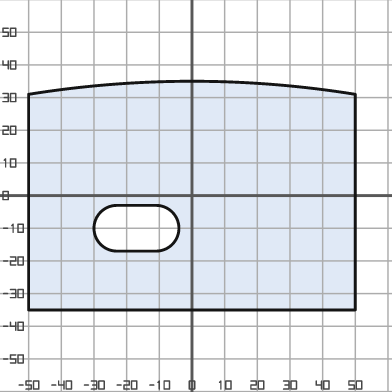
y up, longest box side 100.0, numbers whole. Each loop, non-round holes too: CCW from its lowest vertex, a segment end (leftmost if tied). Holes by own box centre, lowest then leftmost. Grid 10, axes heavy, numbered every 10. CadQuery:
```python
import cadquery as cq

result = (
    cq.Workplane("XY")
    .moveTo(-50.0, -35.0)
    .lineTo(50.0, -35.0)
    .lineTo(50.0, 31.0)
    .threePointArc((0.0, 35.0), (-50.0, 31.0))
    .close()
    .moveTo(-23.0, -17.0)
    .lineTo(-11.0, -17.0)
    .threePointArc((-4.0, -10.0), (-11.0, -3.0))
    .lineTo(-23.0, -3.0)
    .threePointArc((-30.0, -10.0), (-23.0, -17.0))
    .close()
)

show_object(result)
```